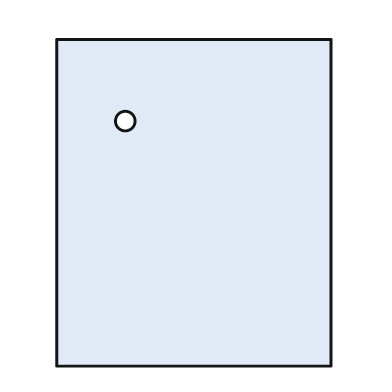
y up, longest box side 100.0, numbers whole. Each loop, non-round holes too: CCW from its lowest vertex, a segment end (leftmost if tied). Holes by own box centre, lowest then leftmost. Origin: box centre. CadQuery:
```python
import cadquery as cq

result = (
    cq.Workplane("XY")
    .moveTo(-42.0, -50.0)
    .lineTo(42.0, -50.0)
    .lineTo(42.0, 50.0)
    .lineTo(-42.0, 50.0)
    .close()
    .moveTo(-21.0, 25.0)
    .circle(3.0)
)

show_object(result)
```